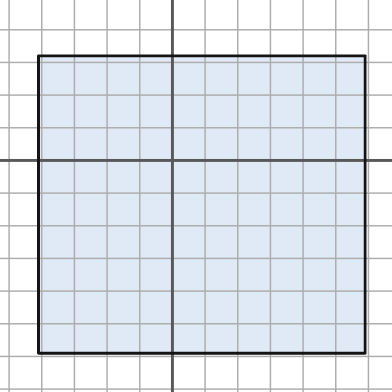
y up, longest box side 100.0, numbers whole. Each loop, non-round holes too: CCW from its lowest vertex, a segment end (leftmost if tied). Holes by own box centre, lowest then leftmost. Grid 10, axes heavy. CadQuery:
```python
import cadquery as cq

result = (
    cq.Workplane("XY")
    .moveTo(-41.0, -59.0)
    .lineTo(59.0, -59.0)
    .lineTo(59.0, 32.0)
    .lineTo(-41.0, 32.0)
    .close()
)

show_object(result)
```